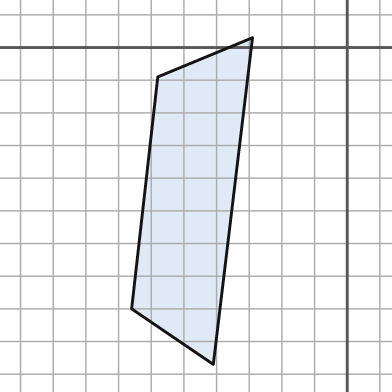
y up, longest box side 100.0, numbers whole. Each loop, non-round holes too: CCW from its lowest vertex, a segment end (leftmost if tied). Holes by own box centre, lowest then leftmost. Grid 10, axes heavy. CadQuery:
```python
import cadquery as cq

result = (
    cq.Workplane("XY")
    .moveTo(-41.0, -97.0)
    .lineTo(-29.0, 3.0)
    .lineTo(-58.0, -9.0)
    .lineTo(-66.0, -80.0)
    .close()
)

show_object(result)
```